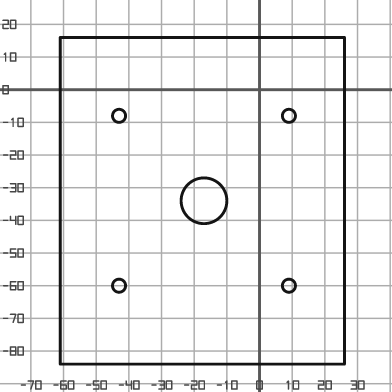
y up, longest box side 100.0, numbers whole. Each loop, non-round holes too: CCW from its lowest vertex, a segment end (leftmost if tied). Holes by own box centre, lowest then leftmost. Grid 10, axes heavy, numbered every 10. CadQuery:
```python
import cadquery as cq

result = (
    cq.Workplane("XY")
    .moveTo(-61.0, -84.0)
    .lineTo(26.0, -84.0)
    .lineTo(26.0, 16.0)
    .lineTo(-61.0, 16.0)
    .close()
    .moveTo(-43.0, -60.0)
    .circle(2.0)
    .moveTo(9.0, -60.0)
    .circle(2.0)
    .moveTo(-17.0, -34.0)
    .circle(7.0)
    .moveTo(-43.0, -8.0)
    .circle(2.0)
    .moveTo(9.0, -8.0)
    .circle(2.0)
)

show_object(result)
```